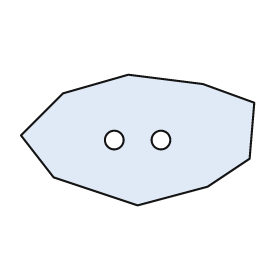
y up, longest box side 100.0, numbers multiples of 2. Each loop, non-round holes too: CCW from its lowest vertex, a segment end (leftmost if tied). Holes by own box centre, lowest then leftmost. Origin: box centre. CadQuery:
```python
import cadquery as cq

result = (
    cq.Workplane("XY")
    .moveTo(0.0, -28.0)
    .lineTo(30.0, -20.0)
    .lineTo(48.0, -8.0)
    .lineTo(50.0, 16.0)
    .lineTo(28.0, 24.0)
    .lineTo(-4.0, 28.0)
    .lineTo(-32.0, 20.0)
    .lineTo(-50.0, 2.0)
    .lineTo(-36.0, -16.0)
    .close()
    .moveTo(-10.0, 0.0)
    .circle(4.0)
    .moveTo(10.0, 0.0)
    .circle(4.0)
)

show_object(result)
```